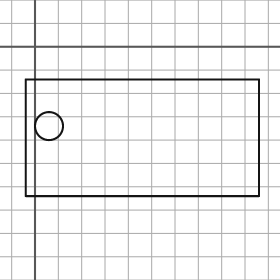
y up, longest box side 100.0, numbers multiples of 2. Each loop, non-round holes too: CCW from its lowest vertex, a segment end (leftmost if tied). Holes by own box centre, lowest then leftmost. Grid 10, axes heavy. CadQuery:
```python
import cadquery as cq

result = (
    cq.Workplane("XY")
    .moveTo(-4.0, -64.0)
    .lineTo(96.0, -64.0)
    .lineTo(96.0, -14.0)
    .lineTo(-4.0, -14.0)
    .close()
    .moveTo(6.0, -34.0)
    .circle(6.0)
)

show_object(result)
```